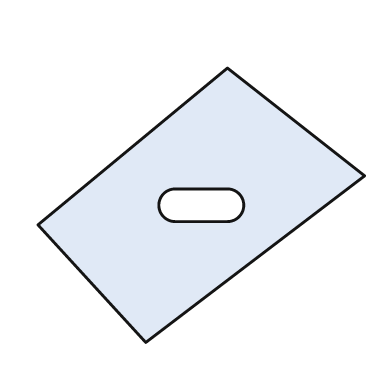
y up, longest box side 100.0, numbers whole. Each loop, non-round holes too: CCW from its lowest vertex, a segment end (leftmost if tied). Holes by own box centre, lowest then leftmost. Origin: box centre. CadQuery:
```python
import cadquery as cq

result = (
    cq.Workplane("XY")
    .moveTo(-17.0, -42.0)
    .lineTo(50.0, 9.0)
    .lineTo(8.0, 42.0)
    .lineTo(-50.0, -6.0)
    .close()
    .moveTo(-8.0, -5.0)
    .lineTo(8.0, -5.0)
    .threePointArc((13.0, 0.0), (8.0, 5.0))
    .lineTo(-8.0, 5.0)
    .threePointArc((-13.0, 0.0), (-8.0, -5.0))
    .close()
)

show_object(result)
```